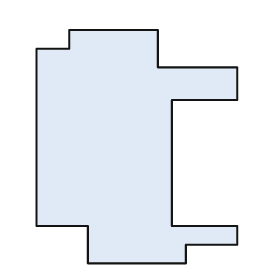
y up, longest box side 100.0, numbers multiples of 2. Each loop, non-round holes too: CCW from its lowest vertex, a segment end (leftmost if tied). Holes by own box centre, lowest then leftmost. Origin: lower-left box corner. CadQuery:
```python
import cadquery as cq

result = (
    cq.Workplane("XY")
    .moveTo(22.0, 0.0)
    .lineTo(64.0, 0.0)
    .lineTo(64.0, 8.0)
    .lineTo(86.0, 8.0)
    .lineTo(86.0, 16.0)
    .lineTo(58.0, 16.0)
    .lineTo(58.0, 70.0)
    .lineTo(86.0, 70.0)
    .lineTo(86.0, 84.0)
    .lineTo(52.0, 84.0)
    .lineTo(52.0, 100.0)
    .lineTo(14.0, 100.0)
    .lineTo(14.0, 92.0)
    .lineTo(0.0, 92.0)
    .lineTo(0.0, 16.0)
    .lineTo(22.0, 16.0)
    .close()
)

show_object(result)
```